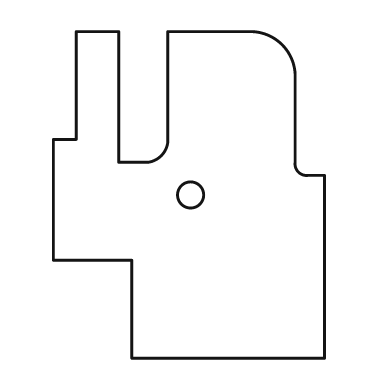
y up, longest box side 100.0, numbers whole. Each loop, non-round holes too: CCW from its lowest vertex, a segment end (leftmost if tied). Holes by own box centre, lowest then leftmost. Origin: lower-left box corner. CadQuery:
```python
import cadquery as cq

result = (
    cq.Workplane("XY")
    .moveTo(24.0, 0.0)
    .lineTo(83.0, 0.0)
    .lineTo(83.0, 56.0)
    .lineTo(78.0, 56.0)
    .threePointArc((75.0, 57.0), (74.0, 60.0))
    .lineTo(74.0, 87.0)
    .threePointArc((70.0, 96.0), (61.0, 100.0))
    .lineTo(35.0, 100.0)
    .lineTo(35.0, 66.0)
    .threePointArc((33.0, 62.0), (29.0, 60.0))
    .lineTo(20.0, 60.0)
    .lineTo(20.0, 100.0)
    .lineTo(7.0, 100.0)
    .lineTo(7.0, 67.0)
    .lineTo(0.0, 67.0)
    .lineTo(0.0, 30.0)
    .lineTo(24.0, 30.0)
    .close()
    .moveTo(42.0, 50.0)
    .circle(4.0)
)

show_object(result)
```